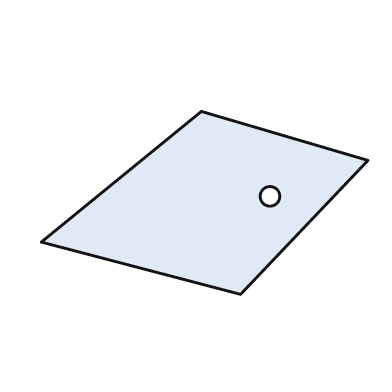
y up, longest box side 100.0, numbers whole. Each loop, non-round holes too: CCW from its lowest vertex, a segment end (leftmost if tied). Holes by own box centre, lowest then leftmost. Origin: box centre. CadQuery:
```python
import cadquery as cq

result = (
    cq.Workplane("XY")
    .moveTo(11.0, -28.0)
    .lineTo(50.0, 13.0)
    .lineTo(-1.0, 28.0)
    .lineTo(-50.0, -12.0)
    .close()
    .moveTo(20.0, 2.0)
    .circle(3.0)
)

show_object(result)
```